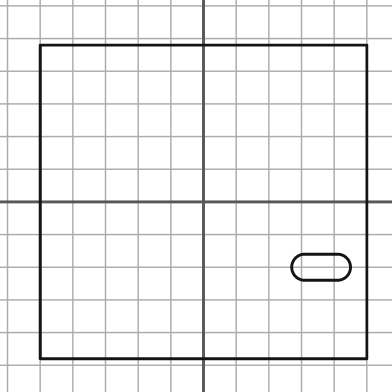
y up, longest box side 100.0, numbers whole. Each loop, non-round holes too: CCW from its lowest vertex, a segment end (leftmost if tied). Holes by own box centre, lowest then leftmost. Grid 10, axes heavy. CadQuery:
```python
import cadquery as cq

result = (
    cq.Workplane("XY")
    .moveTo(-50.0, -48.0)
    .lineTo(50.0, -48.0)
    .lineTo(50.0, 48.0)
    .lineTo(-50.0, 48.0)
    .close()
    .moveTo(31.0, -24.0)
    .lineTo(41.0, -24.0)
    .threePointArc((45.0, -20.0), (41.0, -16.0))
    .lineTo(31.0, -16.0)
    .threePointArc((27.0, -20.0), (31.0, -24.0))
    .close()
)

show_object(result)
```